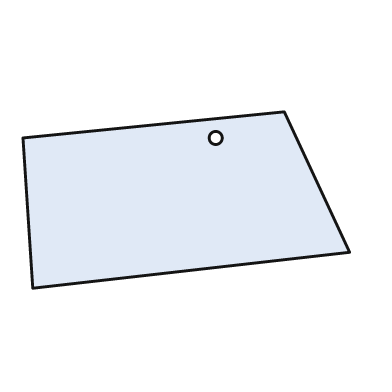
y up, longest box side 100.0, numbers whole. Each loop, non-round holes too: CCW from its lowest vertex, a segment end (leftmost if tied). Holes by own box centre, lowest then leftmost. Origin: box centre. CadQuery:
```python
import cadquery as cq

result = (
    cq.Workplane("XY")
    .moveTo(-47.0, -27.0)
    .lineTo(50.0, -16.0)
    .lineTo(30.0, 27.0)
    .lineTo(-50.0, 19.0)
    .close()
    .moveTo(9.0, 19.0)
    .circle(2.0)
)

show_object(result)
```